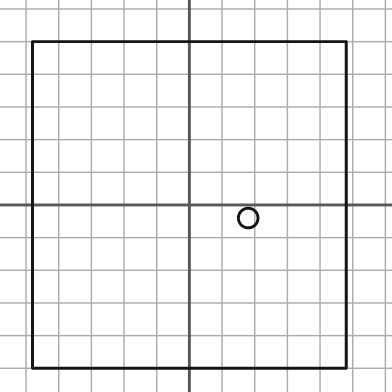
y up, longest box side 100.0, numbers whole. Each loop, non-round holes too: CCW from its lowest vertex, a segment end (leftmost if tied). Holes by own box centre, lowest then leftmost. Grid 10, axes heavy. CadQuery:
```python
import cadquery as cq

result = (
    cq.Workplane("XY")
    .moveTo(-48.0, -50.0)
    .lineTo(48.0, -50.0)
    .lineTo(48.0, 50.0)
    .lineTo(-48.0, 50.0)
    .close()
    .moveTo(18.0, -4.0)
    .circle(3.0)
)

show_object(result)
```